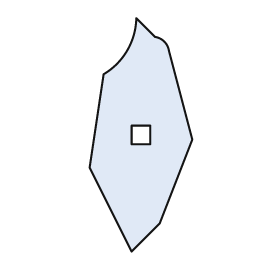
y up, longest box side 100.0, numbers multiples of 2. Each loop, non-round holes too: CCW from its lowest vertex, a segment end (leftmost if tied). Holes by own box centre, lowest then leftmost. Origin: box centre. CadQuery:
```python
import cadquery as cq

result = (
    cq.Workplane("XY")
    .moveTo(-4.0, -50.0)
    .lineTo(8.0, -38.0)
    .lineTo(22.0, -2.0)
    .lineTo(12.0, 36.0)
    .threePointArc((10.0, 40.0), (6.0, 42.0))
    .lineTo(-2.0, 50.0)
    .threePointArc((-6.0, 36.0), (-16.0, 26.0))
    .lineTo(-22.0, -14.0)
    .close()
    .moveTo(-4.0, -4.0)
    .lineTo(4.0, -4.0)
    .lineTo(4.0, 4.0)
    .lineTo(-4.0, 4.0)
    .close()
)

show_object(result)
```